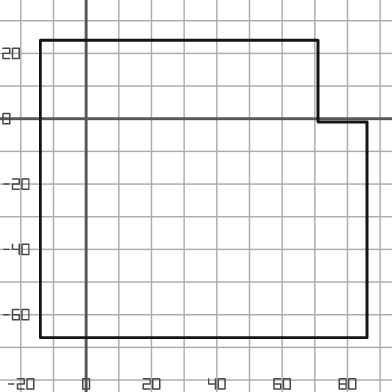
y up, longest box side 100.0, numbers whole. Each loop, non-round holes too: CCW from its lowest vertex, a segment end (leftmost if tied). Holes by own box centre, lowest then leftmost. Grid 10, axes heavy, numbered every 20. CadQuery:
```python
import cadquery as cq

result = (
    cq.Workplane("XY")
    .moveTo(-14.0, -67.0)
    .lineTo(86.0, -67.0)
    .lineTo(86.0, -1.0)
    .lineTo(71.0, -1.0)
    .lineTo(71.0, 24.0)
    .lineTo(-14.0, 24.0)
    .close()
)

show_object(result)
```